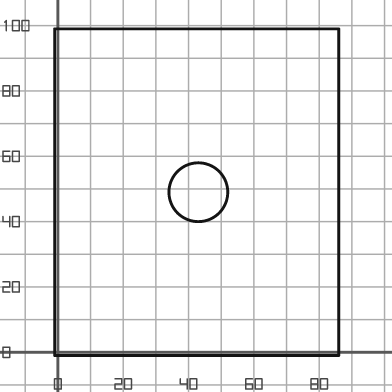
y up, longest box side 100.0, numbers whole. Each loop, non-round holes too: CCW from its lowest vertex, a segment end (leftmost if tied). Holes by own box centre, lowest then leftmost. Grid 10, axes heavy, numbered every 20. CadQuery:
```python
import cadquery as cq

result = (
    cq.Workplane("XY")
    .moveTo(-1.0, -1.0)
    .lineTo(86.0, -1.0)
    .lineTo(86.0, 99.0)
    .lineTo(-1.0, 99.0)
    .close()
    .moveTo(43.0, 49.0)
    .circle(9.0)
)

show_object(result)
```